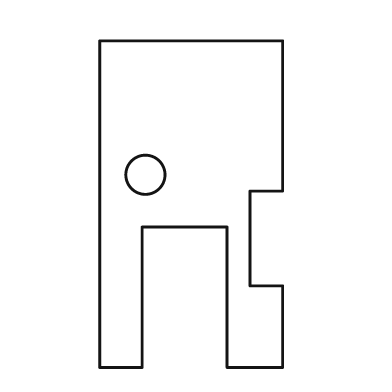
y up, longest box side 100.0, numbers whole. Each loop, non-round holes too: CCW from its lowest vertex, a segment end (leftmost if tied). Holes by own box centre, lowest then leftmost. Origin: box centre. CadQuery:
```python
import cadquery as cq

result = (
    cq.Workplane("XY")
    .moveTo(-28.0, -50.0)
    .lineTo(-15.0, -50.0)
    .lineTo(-15.0, -7.0)
    .lineTo(11.0, -7.0)
    .lineTo(11.0, -50.0)
    .lineTo(28.0, -50.0)
    .lineTo(28.0, -25.0)
    .lineTo(18.0, -25.0)
    .lineTo(18.0, 4.0)
    .lineTo(28.0, 4.0)
    .lineTo(28.0, 50.0)
    .lineTo(-28.0, 50.0)
    .close()
    .moveTo(-14.0, 9.0)
    .circle(6.0)
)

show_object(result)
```